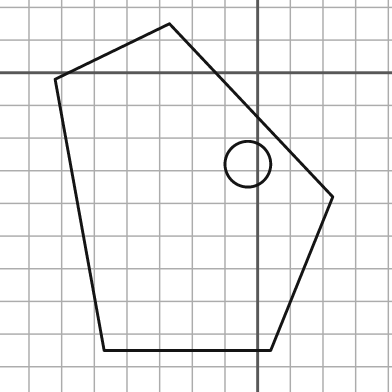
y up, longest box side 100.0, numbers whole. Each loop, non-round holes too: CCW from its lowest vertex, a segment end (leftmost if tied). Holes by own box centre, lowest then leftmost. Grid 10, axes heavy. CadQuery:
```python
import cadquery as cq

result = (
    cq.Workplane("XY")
    .moveTo(-47.0, -85.0)
    .lineTo(4.0, -85.0)
    .lineTo(23.0, -38.0)
    .lineTo(-27.0, 15.0)
    .lineTo(-62.0, -2.0)
    .close()
    .moveTo(-3.0, -28.0)
    .circle(7.0)
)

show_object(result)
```